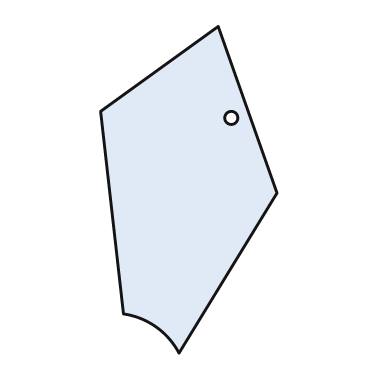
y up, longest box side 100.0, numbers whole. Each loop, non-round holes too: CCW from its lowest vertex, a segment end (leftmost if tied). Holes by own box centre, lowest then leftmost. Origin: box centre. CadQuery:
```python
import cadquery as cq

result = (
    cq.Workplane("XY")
    .moveTo(-3.0, -50.0)
    .lineTo(27.0, -1.0)
    .lineTo(9.0, 50.0)
    .lineTo(-27.0, 24.0)
    .lineTo(-20.0, -38.0)
    .threePointArc((-10.0, -42.0), (-3.0, -50.0))
    .close()
    .moveTo(13.0, 22.0)
    .circle(2.0)
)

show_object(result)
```